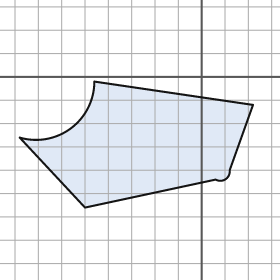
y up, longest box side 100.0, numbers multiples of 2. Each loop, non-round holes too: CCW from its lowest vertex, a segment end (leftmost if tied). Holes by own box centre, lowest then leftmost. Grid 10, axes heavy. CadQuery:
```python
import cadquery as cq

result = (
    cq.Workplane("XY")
    .moveTo(-50.0, -56.0)
    .lineTo(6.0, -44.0)
    .threePointArc((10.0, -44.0), (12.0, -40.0))
    .lineTo(22.0, -12.0)
    .lineTo(-46.0, -2.0)
    .threePointArc((-56.0, -22.0), (-78.0, -26.0))
    .close()
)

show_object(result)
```